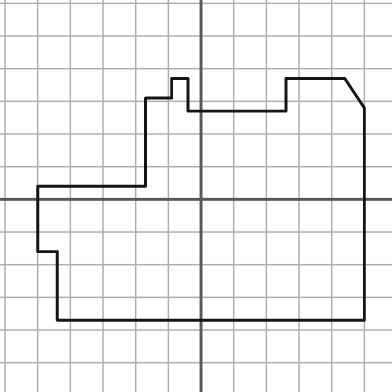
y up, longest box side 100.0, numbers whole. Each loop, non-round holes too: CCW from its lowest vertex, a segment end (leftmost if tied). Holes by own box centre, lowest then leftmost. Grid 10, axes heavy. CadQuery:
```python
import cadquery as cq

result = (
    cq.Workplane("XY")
    .moveTo(-44.0, -37.0)
    .lineTo(50.0, -37.0)
    .lineTo(50.0, 28.0)
    .lineTo(44.0, 37.0)
    .lineTo(26.0, 37.0)
    .lineTo(26.0, 27.0)
    .lineTo(-4.0, 27.0)
    .lineTo(-4.0, 37.0)
    .lineTo(-9.0, 37.0)
    .lineTo(-9.0, 31.0)
    .lineTo(-17.0, 31.0)
    .lineTo(-17.0, 4.0)
    .lineTo(-50.0, 4.0)
    .lineTo(-50.0, -16.0)
    .lineTo(-44.0, -16.0)
    .close()
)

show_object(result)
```